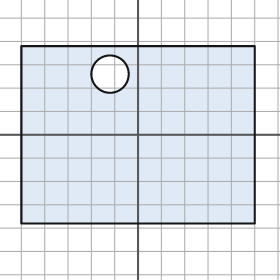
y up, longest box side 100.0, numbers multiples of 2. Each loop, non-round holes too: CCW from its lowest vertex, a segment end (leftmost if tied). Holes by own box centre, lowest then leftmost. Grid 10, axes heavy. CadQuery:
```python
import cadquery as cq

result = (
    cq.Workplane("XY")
    .moveTo(-50.0, -38.0)
    .lineTo(50.0, -38.0)
    .lineTo(50.0, 38.0)
    .lineTo(-50.0, 38.0)
    .close()
    .moveTo(-12.0, 26.0)
    .circle(8.0)
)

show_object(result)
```